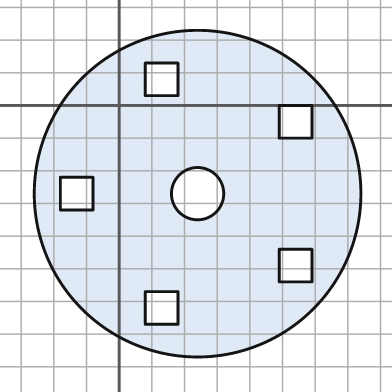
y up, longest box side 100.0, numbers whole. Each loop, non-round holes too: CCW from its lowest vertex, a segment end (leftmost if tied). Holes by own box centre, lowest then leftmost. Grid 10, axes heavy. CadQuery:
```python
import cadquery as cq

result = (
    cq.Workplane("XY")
    .moveTo(24.0, -27.0)
    .circle(50.0)
    .moveTo(8.0, -67.0)
    .lineTo(18.0, -67.0)
    .lineTo(18.0, -57.0)
    .lineTo(8.0, -57.0)
    .close()
    .moveTo(49.0, -54.0)
    .lineTo(59.0, -54.0)
    .lineTo(59.0, -44.0)
    .lineTo(49.0, -44.0)
    .close()
    .moveTo(-18.0, -32.0)
    .lineTo(-8.0, -32.0)
    .lineTo(-8.0, -22.0)
    .lineTo(-18.0, -22.0)
    .close()
    .moveTo(24.0, -27.0)
    .circle(8.0)
    .moveTo(49.0, -10.0)
    .lineTo(59.0, -10.0)
    .lineTo(59.0, 0.0)
    .lineTo(49.0, 0.0)
    .close()
    .moveTo(8.0, 3.0)
    .lineTo(18.0, 3.0)
    .lineTo(18.0, 13.0)
    .lineTo(8.0, 13.0)
    .close()
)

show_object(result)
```